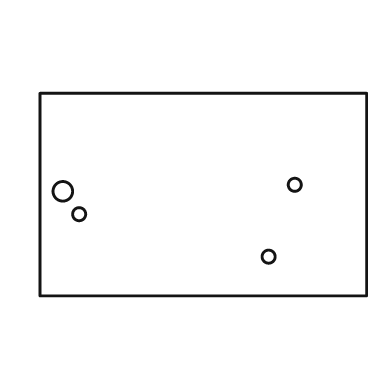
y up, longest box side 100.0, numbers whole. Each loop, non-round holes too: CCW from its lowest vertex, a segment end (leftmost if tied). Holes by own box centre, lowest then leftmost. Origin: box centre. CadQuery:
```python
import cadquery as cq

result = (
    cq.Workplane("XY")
    .moveTo(-50.0, -31.0)
    .lineTo(50.0, -31.0)
    .lineTo(50.0, 31.0)
    .lineTo(-50.0, 31.0)
    .close()
    .moveTo(20.0, -19.0)
    .circle(2.0)
    .moveTo(-38.0, -6.0)
    .circle(2.0)
    .moveTo(-43.0, 1.0)
    .circle(3.0)
    .moveTo(28.0, 3.0)
    .circle(2.0)
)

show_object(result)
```